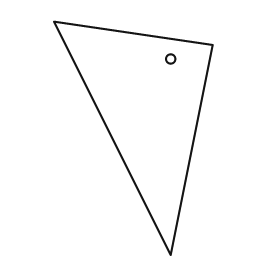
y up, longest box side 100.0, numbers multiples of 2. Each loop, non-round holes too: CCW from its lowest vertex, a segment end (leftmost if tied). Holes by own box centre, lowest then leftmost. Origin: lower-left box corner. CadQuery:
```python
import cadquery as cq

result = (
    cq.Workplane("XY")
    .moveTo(50.0, 0.0)
    .lineTo(68.0, 90.0)
    .lineTo(0.0, 100.0)
    .close()
    .moveTo(50.0, 84.0)
    .circle(2.0)
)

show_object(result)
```